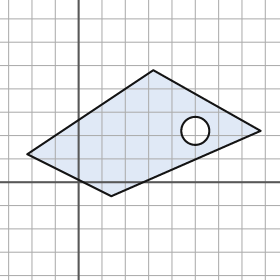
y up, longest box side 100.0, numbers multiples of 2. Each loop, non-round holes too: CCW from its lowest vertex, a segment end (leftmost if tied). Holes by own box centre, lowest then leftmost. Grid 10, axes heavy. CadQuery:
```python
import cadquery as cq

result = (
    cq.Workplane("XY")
    .moveTo(14.0, -6.0)
    .lineTo(78.0, 22.0)
    .lineTo(32.0, 48.0)
    .lineTo(-22.0, 12.0)
    .close()
    .moveTo(50.0, 22.0)
    .circle(6.0)
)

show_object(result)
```